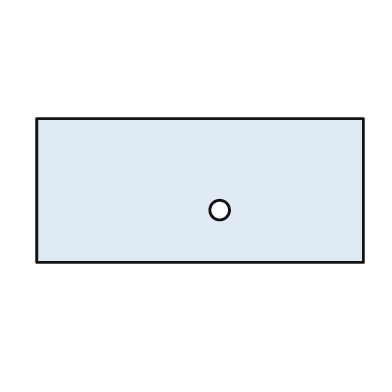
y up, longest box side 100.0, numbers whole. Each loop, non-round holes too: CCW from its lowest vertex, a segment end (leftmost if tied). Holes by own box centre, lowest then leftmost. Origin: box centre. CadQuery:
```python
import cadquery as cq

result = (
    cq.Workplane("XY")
    .moveTo(-50.0, -22.0)
    .lineTo(50.0, -22.0)
    .lineTo(50.0, 22.0)
    .lineTo(-50.0, 22.0)
    .close()
    .moveTo(6.0, -6.0)
    .circle(3.0)
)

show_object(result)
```